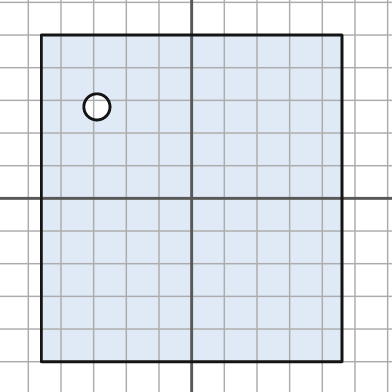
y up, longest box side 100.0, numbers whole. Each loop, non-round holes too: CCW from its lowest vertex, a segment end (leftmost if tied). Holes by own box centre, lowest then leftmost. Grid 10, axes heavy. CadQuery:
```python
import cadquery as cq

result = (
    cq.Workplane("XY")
    .moveTo(-46.0, -50.0)
    .lineTo(46.0, -50.0)
    .lineTo(46.0, 50.0)
    .lineTo(-46.0, 50.0)
    .close()
    .moveTo(-29.0, 28.0)
    .circle(4.0)
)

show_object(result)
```